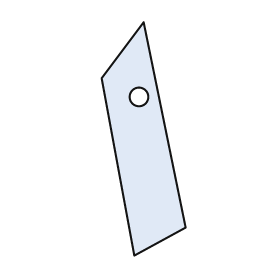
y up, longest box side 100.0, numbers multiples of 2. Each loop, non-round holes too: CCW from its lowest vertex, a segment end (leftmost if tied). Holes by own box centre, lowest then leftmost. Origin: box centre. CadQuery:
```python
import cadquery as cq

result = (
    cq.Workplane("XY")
    .moveTo(-4.0, -50.0)
    .lineTo(18.0, -38.0)
    .lineTo(0.0, 50.0)
    .lineTo(-18.0, 26.0)
    .close()
    .moveTo(-2.0, 18.0)
    .circle(4.0)
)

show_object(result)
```